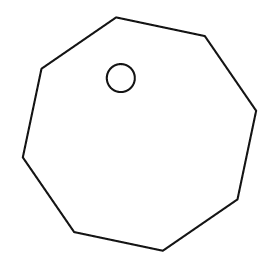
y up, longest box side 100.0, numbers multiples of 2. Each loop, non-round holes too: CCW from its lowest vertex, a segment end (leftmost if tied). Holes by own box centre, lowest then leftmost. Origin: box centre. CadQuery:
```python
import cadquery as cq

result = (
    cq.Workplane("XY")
    .moveTo(10.0, -50.0)
    .lineTo(42.0, -28.0)
    .lineTo(50.0, 10.0)
    .lineTo(28.0, 42.0)
    .lineTo(-10.0, 50.0)
    .lineTo(-42.0, 28.0)
    .lineTo(-50.0, -10.0)
    .lineTo(-28.0, -42.0)
    .close()
    .moveTo(-8.0, 24.0)
    .circle(6.0)
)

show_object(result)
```